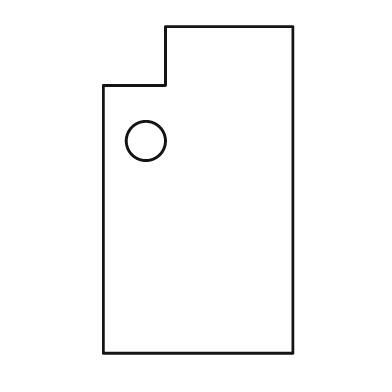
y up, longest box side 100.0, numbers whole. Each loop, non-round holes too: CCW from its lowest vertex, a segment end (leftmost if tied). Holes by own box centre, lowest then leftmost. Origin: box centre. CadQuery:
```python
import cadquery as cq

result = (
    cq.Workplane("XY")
    .moveTo(-29.0, -50.0)
    .lineTo(29.0, -50.0)
    .lineTo(29.0, 50.0)
    .lineTo(-10.0, 50.0)
    .lineTo(-10.0, 32.0)
    .lineTo(-29.0, 32.0)
    .close()
    .moveTo(-16.0, 15.0)
    .circle(6.0)
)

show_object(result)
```